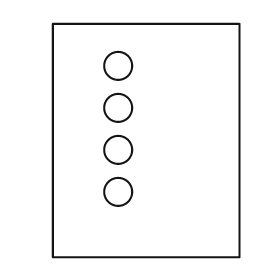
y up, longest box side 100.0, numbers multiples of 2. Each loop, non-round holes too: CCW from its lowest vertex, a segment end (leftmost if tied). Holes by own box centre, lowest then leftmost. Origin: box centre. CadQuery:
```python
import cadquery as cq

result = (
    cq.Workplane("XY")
    .moveTo(-40.0, -50.0)
    .lineTo(40.0, -50.0)
    .lineTo(40.0, 50.0)
    .lineTo(-40.0, 50.0)
    .close()
    .moveTo(-12.0, -22.0)
    .circle(6.0)
    .moveTo(-12.0, -4.0)
    .circle(6.0)
    .moveTo(-12.0, 14.0)
    .circle(6.0)
    .moveTo(-12.0, 32.0)
    .circle(6.0)
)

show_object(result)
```